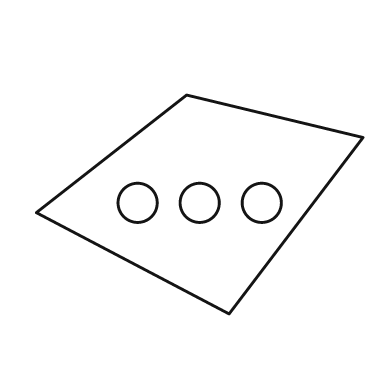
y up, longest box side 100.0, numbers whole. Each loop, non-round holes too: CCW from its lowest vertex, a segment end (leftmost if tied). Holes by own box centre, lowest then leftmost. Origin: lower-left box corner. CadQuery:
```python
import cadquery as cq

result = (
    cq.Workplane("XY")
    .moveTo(59.0, 0.0)
    .lineTo(100.0, 54.0)
    .lineTo(46.0, 67.0)
    .lineTo(0.0, 31.0)
    .close()
    .moveTo(31.0, 34.0)
    .circle(6.0)
    .moveTo(50.0, 34.0)
    .circle(6.0)
    .moveTo(69.0, 34.0)
    .circle(6.0)
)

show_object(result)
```